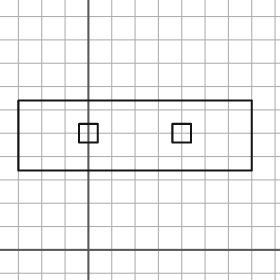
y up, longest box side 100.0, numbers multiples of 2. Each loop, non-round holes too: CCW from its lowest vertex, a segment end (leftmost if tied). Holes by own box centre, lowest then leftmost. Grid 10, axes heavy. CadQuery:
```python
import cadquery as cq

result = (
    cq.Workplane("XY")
    .moveTo(-30.0, 34.0)
    .lineTo(70.0, 34.0)
    .lineTo(70.0, 64.0)
    .lineTo(-30.0, 64.0)
    .close()
    .moveTo(-4.0, 46.0)
    .lineTo(4.0, 46.0)
    .lineTo(4.0, 54.0)
    .lineTo(-4.0, 54.0)
    .close()
    .moveTo(36.0, 46.0)
    .lineTo(44.0, 46.0)
    .lineTo(44.0, 54.0)
    .lineTo(36.0, 54.0)
    .close()
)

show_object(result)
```